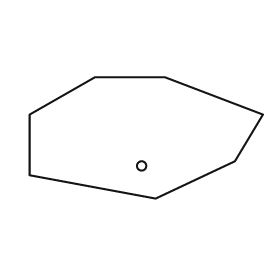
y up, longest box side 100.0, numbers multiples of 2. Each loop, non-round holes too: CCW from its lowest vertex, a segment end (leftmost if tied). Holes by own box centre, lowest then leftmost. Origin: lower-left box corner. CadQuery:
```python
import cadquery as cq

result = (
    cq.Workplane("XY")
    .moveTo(54.0, 0.0)
    .lineTo(88.0, 16.0)
    .lineTo(100.0, 36.0)
    .lineTo(58.0, 52.0)
    .lineTo(28.0, 52.0)
    .lineTo(0.0, 36.0)
    .lineTo(0.0, 10.0)
    .close()
    .moveTo(48.0, 14.0)
    .circle(2.0)
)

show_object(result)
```